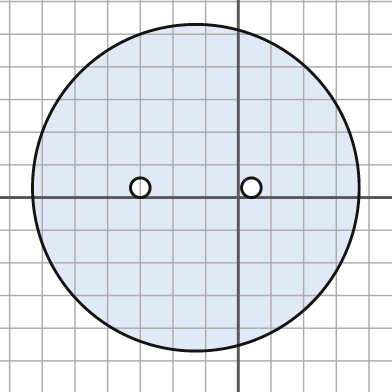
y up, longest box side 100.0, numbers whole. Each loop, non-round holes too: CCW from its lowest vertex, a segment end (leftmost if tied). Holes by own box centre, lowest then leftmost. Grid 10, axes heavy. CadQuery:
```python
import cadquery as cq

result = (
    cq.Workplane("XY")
    .moveTo(-13.0, 3.0)
    .circle(50.0)
    .moveTo(-30.0, 3.0)
    .circle(3.0)
    .moveTo(4.0, 3.0)
    .circle(3.0)
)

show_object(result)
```